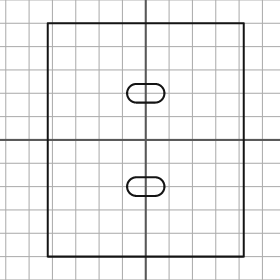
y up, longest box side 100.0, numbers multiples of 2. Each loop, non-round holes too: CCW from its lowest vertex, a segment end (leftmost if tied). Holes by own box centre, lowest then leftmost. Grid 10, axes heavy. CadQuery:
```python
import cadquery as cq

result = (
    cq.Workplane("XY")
    .moveTo(-42.0, -50.0)
    .lineTo(42.0, -50.0)
    .lineTo(42.0, 50.0)
    .lineTo(-42.0, 50.0)
    .close()
    .moveTo(-4.0, -24.0)
    .lineTo(4.0, -24.0)
    .threePointArc((8.0, -20.0), (4.0, -16.0))
    .lineTo(-4.0, -16.0)
    .threePointArc((-8.0, -20.0), (-4.0, -24.0))
    .close()
    .moveTo(-4.0, 16.0)
    .lineTo(4.0, 16.0)
    .threePointArc((8.0, 20.0), (4.0, 24.0))
    .lineTo(-4.0, 24.0)
    .threePointArc((-8.0, 20.0), (-4.0, 16.0))
    .close()
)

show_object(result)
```